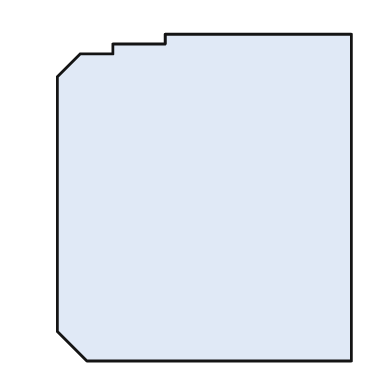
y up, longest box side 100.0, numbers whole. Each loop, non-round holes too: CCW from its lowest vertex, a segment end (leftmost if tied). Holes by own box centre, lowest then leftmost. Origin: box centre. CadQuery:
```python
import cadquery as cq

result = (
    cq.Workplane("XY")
    .moveTo(-36.0, -50.0)
    .lineTo(45.0, -50.0)
    .lineTo(45.0, 50.0)
    .lineTo(-12.0, 50.0)
    .lineTo(-12.0, 47.0)
    .lineTo(-28.0, 47.0)
    .lineTo(-28.0, 44.0)
    .lineTo(-38.0, 44.0)
    .lineTo(-45.0, 37.0)
    .lineTo(-45.0, -41.0)
    .close()
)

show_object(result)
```